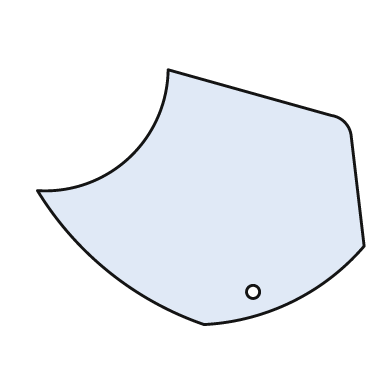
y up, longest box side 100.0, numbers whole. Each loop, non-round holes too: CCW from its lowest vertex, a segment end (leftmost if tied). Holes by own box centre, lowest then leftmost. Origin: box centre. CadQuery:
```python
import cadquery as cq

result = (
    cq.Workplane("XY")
    .moveTo(1.0, -39.0)
    .threePointArc((28.0, -32.0), (50.0, -15.0))
    .lineTo(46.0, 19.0)
    .threePointArc((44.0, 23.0), (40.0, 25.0))
    .lineTo(-10.0, 39.0)
    .threePointArc((-22.0, 12.0), (-50.0, 2.0))
    .threePointArc((-28.0, -23.0), (1.0, -39.0))
    .close()
    .moveTo(16.0, -29.0)
    .circle(2.0)
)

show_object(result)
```